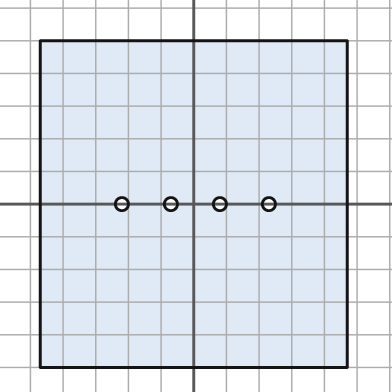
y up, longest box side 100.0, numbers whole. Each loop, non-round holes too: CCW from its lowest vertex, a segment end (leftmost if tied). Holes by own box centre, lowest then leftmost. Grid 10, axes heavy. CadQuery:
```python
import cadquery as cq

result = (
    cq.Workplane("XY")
    .moveTo(-47.0, -50.0)
    .lineTo(47.0, -50.0)
    .lineTo(47.0, 50.0)
    .lineTo(-47.0, 50.0)
    .close()
    .moveTo(-22.0, 0.0)
    .circle(2.0)
    .moveTo(-7.0, 0.0)
    .circle(2.0)
    .moveTo(8.0, 0.0)
    .circle(2.0)
    .moveTo(23.0, 0.0)
    .circle(2.0)
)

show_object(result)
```